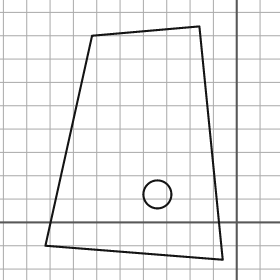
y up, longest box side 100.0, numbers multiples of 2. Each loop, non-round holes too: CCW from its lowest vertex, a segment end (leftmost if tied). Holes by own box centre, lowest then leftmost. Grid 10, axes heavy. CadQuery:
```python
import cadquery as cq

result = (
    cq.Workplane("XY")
    .moveTo(-6.0, -16.0)
    .lineTo(-16.0, 84.0)
    .lineTo(-62.0, 80.0)
    .lineTo(-82.0, -10.0)
    .close()
    .moveTo(-34.0, 12.0)
    .circle(6.0)
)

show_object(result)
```